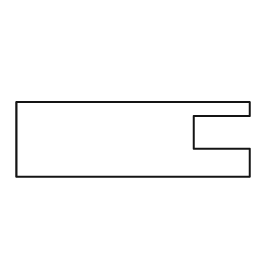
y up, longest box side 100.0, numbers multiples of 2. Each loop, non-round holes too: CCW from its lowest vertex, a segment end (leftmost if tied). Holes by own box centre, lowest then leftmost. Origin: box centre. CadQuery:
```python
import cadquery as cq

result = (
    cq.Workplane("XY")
    .moveTo(-50.0, -16.0)
    .lineTo(50.0, -16.0)
    .lineTo(50.0, -4.0)
    .lineTo(26.0, -4.0)
    .lineTo(26.0, 10.0)
    .lineTo(50.0, 10.0)
    .lineTo(50.0, 16.0)
    .lineTo(-50.0, 16.0)
    .close()
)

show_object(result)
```